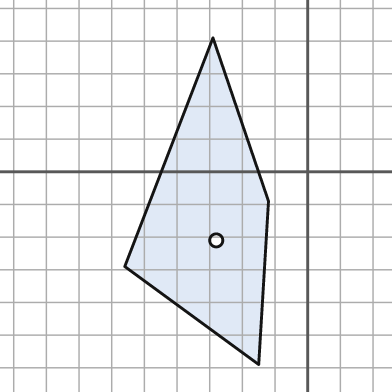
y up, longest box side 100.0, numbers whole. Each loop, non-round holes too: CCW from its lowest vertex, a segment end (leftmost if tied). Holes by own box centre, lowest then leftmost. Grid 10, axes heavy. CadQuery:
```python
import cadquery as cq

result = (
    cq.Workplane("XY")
    .moveTo(-15.0, -59.0)
    .lineTo(-12.0, -9.0)
    .lineTo(-29.0, 41.0)
    .lineTo(-56.0, -29.0)
    .close()
    .moveTo(-28.0, -21.0)
    .circle(2.0)
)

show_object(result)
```